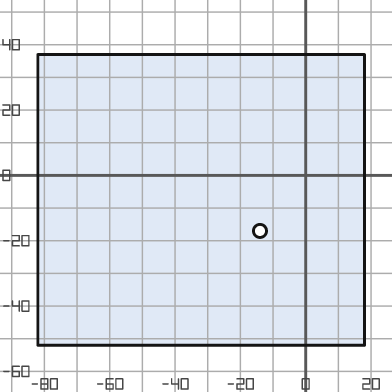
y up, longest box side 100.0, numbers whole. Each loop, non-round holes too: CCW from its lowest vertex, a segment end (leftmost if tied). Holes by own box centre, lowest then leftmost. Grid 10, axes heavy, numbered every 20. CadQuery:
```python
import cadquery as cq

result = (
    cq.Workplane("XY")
    .moveTo(-82.0, -52.0)
    .lineTo(18.0, -52.0)
    .lineTo(18.0, 37.0)
    .lineTo(-82.0, 37.0)
    .close()
    .moveTo(-14.0, -17.0)
    .circle(2.0)
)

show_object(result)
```